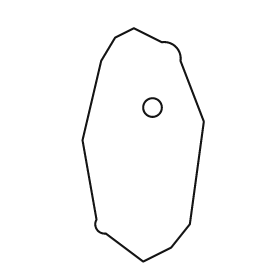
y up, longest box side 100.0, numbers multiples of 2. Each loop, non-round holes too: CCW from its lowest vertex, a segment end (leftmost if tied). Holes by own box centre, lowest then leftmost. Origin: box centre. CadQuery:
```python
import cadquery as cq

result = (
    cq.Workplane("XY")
    .moveTo(0.0, -50.0)
    .lineTo(12.0, -44.0)
    .lineTo(20.0, -34.0)
    .lineTo(26.0, 10.0)
    .lineTo(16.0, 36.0)
    .threePointArc((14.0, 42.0), (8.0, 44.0))
    .lineTo(-4.0, 50.0)
    .lineTo(-12.0, 46.0)
    .lineTo(-18.0, 36.0)
    .lineTo(-26.0, 2.0)
    .lineTo(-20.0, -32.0)
    .threePointArc((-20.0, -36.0), (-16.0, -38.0))
    .close()
    .moveTo(4.0, 16.0)
    .circle(4.0)
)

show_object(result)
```